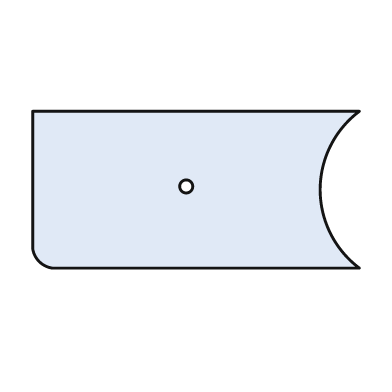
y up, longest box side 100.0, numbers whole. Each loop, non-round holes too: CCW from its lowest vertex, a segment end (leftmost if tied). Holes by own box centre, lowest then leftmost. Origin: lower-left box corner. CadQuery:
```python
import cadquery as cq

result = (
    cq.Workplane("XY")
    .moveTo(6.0, 0.0)
    .lineTo(100.0, 0.0)
    .threePointArc((88.0, 24.0), (100.0, 48.0))
    .lineTo(0.0, 48.0)
    .lineTo(0.0, 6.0)
    .threePointArc((2.0, 2.0), (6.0, 0.0))
    .close()
    .moveTo(47.0, 25.0)
    .circle(2.0)
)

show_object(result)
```